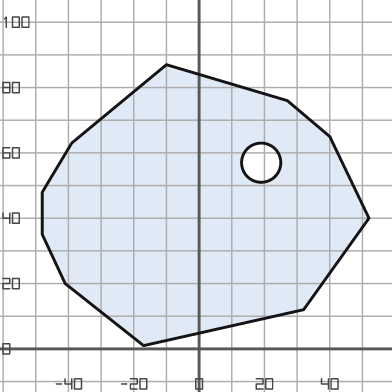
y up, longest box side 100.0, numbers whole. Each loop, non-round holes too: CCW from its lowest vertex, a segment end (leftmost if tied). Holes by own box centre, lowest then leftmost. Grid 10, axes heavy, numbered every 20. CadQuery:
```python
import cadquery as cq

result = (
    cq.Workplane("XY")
    .moveTo(-17.0, 1.0)
    .lineTo(32.0, 12.0)
    .lineTo(52.0, 40.0)
    .lineTo(40.0, 65.0)
    .lineTo(27.0, 76.0)
    .lineTo(-10.0, 87.0)
    .lineTo(-39.0, 63.0)
    .lineTo(-48.0, 48.0)
    .lineTo(-48.0, 35.0)
    .lineTo(-41.0, 20.0)
    .close()
    .moveTo(19.0, 57.0)
    .circle(6.0)
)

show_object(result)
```